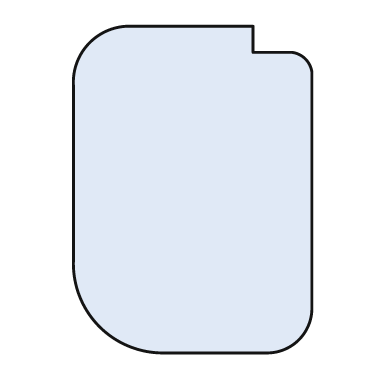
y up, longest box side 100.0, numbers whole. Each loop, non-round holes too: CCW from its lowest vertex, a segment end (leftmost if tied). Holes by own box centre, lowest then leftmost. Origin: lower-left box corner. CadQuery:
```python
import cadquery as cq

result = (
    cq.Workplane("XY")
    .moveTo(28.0, 0.0)
    .lineTo(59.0, 0.0)
    .threePointArc((69.0, 4.0), (73.0, 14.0))
    .lineTo(73.0, 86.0)
    .threePointArc((71.0, 90.0), (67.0, 92.0))
    .lineTo(55.0, 92.0)
    .lineTo(55.0, 100.0)
    .lineTo(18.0, 100.0)
    .threePointArc((5.0, 95.0), (0.0, 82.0))
    .lineTo(0.0, 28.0)
    .threePointArc((8.0, 8.0), (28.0, 0.0))
    .close()
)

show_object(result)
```